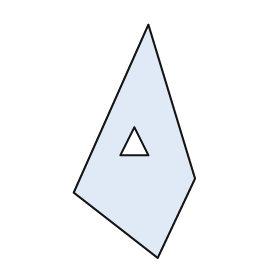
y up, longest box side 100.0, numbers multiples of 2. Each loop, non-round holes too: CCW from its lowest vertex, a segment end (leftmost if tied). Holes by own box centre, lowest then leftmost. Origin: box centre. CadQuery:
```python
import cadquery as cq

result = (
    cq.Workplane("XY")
    .moveTo(10.0, -50.0)
    .lineTo(26.0, -16.0)
    .lineTo(6.0, 50.0)
    .lineTo(-26.0, -22.0)
    .close()
    .moveTo(-6.0, -6.0)
    .lineTo(6.0, -6.0)
    .lineTo(0.0, 6.0)
    .close()
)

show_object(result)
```